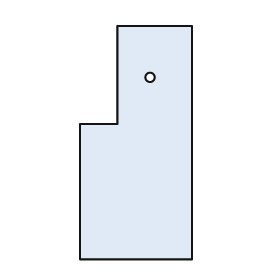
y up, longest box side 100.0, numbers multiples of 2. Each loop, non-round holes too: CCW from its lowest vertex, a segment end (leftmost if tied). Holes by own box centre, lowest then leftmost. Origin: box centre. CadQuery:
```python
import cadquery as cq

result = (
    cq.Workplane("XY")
    .moveTo(-24.0, -50.0)
    .lineTo(24.0, -50.0)
    .lineTo(24.0, 50.0)
    .lineTo(-8.0, 50.0)
    .lineTo(-8.0, 8.0)
    .lineTo(-24.0, 8.0)
    .close()
    .moveTo(6.0, 28.0)
    .circle(2.0)
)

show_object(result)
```